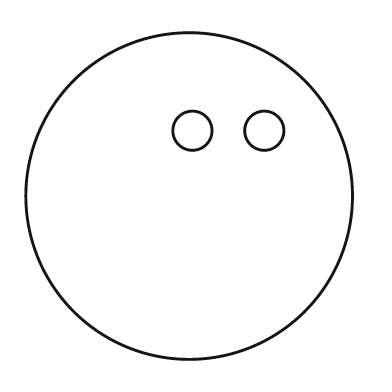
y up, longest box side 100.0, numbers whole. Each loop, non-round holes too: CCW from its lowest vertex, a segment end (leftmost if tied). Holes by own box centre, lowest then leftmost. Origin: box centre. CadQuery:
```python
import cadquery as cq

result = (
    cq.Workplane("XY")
    .moveTo(0.0, 0.0)
    .circle(50.0)
    .moveTo(1.0, 20.0)
    .circle(6.0)
    .moveTo(23.0, 20.0)
    .circle(6.0)
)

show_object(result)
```